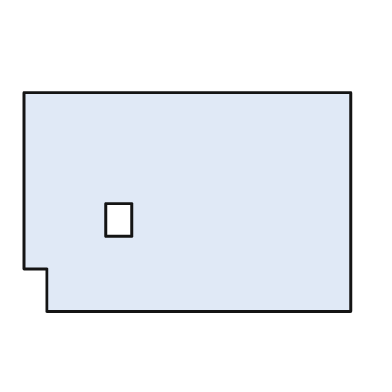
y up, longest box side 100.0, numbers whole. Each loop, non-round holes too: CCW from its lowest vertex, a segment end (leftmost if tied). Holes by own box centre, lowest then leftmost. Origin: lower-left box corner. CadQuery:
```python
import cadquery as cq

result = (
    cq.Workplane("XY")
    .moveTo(7.0, 0.0)
    .lineTo(100.0, 0.0)
    .lineTo(100.0, 67.0)
    .lineTo(0.0, 67.0)
    .lineTo(0.0, 13.0)
    .lineTo(7.0, 13.0)
    .close()
    .moveTo(25.0, 23.0)
    .lineTo(33.0, 23.0)
    .lineTo(33.0, 33.0)
    .lineTo(25.0, 33.0)
    .close()
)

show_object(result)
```